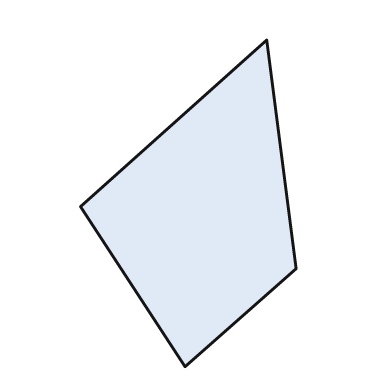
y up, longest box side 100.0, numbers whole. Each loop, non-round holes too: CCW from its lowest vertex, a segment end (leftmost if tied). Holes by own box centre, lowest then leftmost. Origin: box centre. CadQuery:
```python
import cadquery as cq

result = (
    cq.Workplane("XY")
    .moveTo(-1.0, -50.0)
    .lineTo(33.0, -20.0)
    .lineTo(24.0, 50.0)
    .lineTo(-33.0, -1.0)
    .close()
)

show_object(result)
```